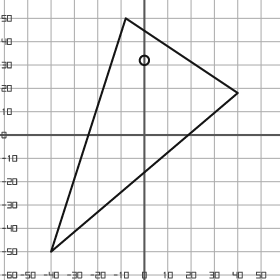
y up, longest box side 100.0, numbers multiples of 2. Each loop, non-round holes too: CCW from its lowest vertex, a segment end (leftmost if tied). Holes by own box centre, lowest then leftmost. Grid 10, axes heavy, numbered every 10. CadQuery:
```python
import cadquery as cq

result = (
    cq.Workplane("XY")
    .moveTo(-40.0, -50.0)
    .lineTo(40.0, 18.0)
    .lineTo(-8.0, 50.0)
    .close()
    .moveTo(0.0, 32.0)
    .circle(2.0)
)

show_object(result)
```